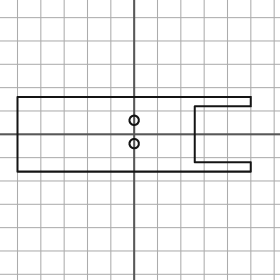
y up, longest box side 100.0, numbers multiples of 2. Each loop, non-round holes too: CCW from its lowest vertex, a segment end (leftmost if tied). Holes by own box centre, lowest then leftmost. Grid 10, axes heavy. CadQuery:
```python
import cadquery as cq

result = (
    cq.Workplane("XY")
    .moveTo(-50.0, -16.0)
    .lineTo(50.0, -16.0)
    .lineTo(50.0, -12.0)
    .lineTo(26.0, -12.0)
    .lineTo(26.0, 12.0)
    .lineTo(50.0, 12.0)
    .lineTo(50.0, 16.0)
    .lineTo(-50.0, 16.0)
    .close()
    .moveTo(0.0, -4.0)
    .circle(2.0)
    .moveTo(0.0, 6.0)
    .circle(2.0)
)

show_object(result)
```